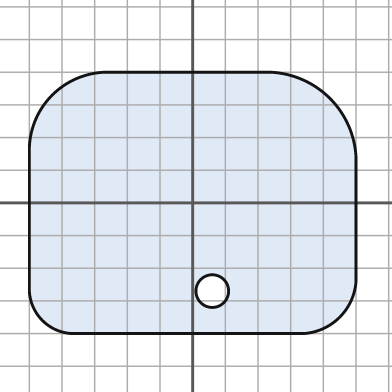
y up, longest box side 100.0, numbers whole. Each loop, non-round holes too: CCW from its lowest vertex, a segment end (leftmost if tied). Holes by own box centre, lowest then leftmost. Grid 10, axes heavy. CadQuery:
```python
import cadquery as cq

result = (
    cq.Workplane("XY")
    .moveTo(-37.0, -40.0)
    .lineTo(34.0, -40.0)
    .threePointArc((45.0, -35.0), (50.0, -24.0))
    .lineTo(50.0, 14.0)
    .threePointArc((42.0, 32.0), (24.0, 40.0))
    .lineTo(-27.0, 40.0)
    .threePointArc((-43.0, 33.0), (-50.0, 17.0))
    .lineTo(-50.0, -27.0)
    .threePointArc((-46.0, -36.0), (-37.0, -40.0))
    .close()
    .moveTo(6.0, -27.0)
    .circle(5.0)
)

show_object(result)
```